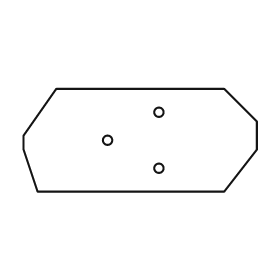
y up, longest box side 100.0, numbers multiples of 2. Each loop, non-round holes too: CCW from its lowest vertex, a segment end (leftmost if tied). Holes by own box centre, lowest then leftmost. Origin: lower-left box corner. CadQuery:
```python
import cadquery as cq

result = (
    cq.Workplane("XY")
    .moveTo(6.0, 0.0)
    .lineTo(86.0, 0.0)
    .lineTo(100.0, 18.0)
    .lineTo(100.0, 30.0)
    .lineTo(86.0, 44.0)
    .lineTo(14.0, 44.0)
    .lineTo(0.0, 24.0)
    .lineTo(0.0, 18.0)
    .close()
    .moveTo(58.0, 10.0)
    .circle(2.0)
    .moveTo(36.0, 22.0)
    .circle(2.0)
    .moveTo(58.0, 34.0)
    .circle(2.0)
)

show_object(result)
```